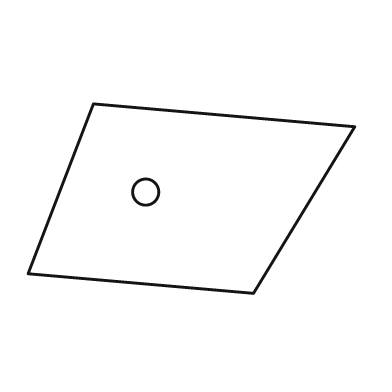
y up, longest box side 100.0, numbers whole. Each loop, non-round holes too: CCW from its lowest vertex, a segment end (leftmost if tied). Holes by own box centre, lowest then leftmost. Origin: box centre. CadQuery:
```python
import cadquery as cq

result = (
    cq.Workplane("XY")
    .moveTo(19.0, -29.0)
    .lineTo(50.0, 22.0)
    .lineTo(-30.0, 29.0)
    .lineTo(-50.0, -23.0)
    .close()
    .moveTo(-14.0, 2.0)
    .circle(4.0)
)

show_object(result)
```